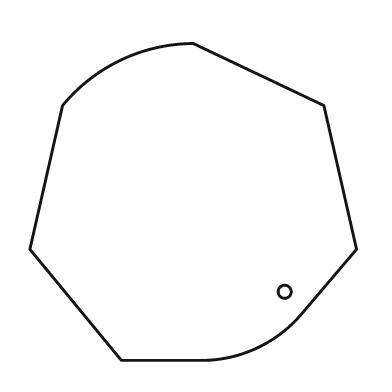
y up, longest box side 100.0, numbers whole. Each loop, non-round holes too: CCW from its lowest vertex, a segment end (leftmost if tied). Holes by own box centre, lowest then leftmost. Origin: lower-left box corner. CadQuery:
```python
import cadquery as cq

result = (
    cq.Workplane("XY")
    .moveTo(28.0, 0.0)
    .lineTo(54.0, 0.0)
    .threePointArc((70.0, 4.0), (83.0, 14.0))
    .lineTo(100.0, 34.0)
    .lineTo(90.0, 78.0)
    .lineTo(50.0, 97.0)
    .threePointArc((28.0, 92.0), (10.0, 78.0))
    .lineTo(0.0, 34.0)
    .close()
    .moveTo(78.0, 21.0)
    .circle(2.0)
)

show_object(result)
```